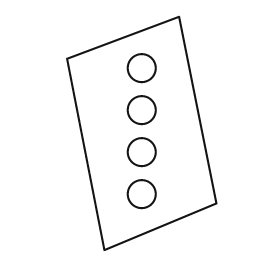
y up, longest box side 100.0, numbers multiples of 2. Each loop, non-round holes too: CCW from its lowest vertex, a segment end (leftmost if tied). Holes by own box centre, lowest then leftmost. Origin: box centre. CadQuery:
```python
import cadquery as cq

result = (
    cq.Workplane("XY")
    .moveTo(-16.0, -50.0)
    .lineTo(32.0, -30.0)
    .lineTo(16.0, 50.0)
    .lineTo(-32.0, 32.0)
    .close()
    .moveTo(0.0, -26.0)
    .circle(6.0)
    .moveTo(0.0, -8.0)
    .circle(6.0)
    .moveTo(0.0, 10.0)
    .circle(6.0)
    .moveTo(0.0, 28.0)
    .circle(6.0)
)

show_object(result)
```